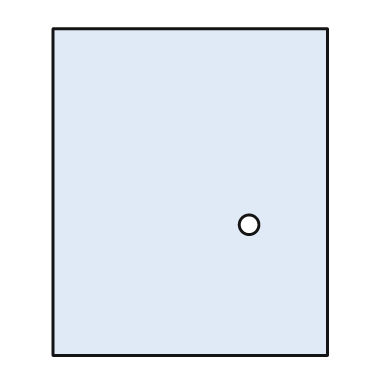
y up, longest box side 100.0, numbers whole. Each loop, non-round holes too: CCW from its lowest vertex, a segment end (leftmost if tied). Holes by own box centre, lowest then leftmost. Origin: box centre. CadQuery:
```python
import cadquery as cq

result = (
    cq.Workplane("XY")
    .moveTo(-42.0, -50.0)
    .lineTo(42.0, -50.0)
    .lineTo(42.0, 50.0)
    .lineTo(-42.0, 50.0)
    .close()
    .moveTo(18.0, -10.0)
    .circle(3.0)
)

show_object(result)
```